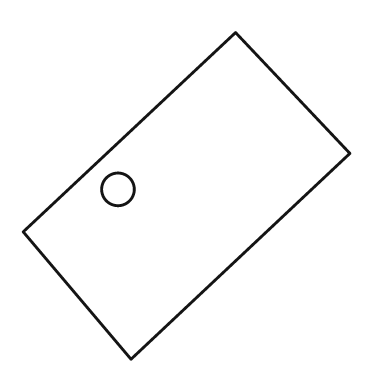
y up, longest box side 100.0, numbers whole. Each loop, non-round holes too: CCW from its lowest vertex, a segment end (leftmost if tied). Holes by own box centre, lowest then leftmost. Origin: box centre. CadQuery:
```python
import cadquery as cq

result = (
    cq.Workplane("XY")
    .moveTo(-17.0, -50.0)
    .lineTo(50.0, 13.0)
    .lineTo(15.0, 50.0)
    .lineTo(-50.0, -11.0)
    .close()
    .moveTo(-21.0, 2.0)
    .circle(5.0)
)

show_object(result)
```